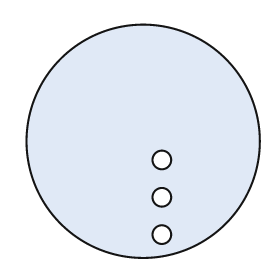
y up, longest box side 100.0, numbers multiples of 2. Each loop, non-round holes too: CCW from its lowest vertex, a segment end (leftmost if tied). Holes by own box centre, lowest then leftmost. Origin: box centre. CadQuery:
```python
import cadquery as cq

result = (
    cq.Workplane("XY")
    .moveTo(0.0, 0.0)
    .circle(50.0)
    .moveTo(8.0, -40.0)
    .circle(4.0)
    .moveTo(8.0, -24.0)
    .circle(4.0)
    .moveTo(8.0, -8.0)
    .circle(4.0)
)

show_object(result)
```